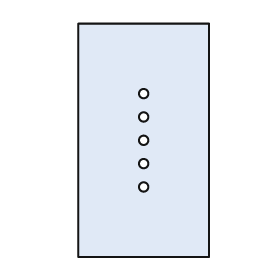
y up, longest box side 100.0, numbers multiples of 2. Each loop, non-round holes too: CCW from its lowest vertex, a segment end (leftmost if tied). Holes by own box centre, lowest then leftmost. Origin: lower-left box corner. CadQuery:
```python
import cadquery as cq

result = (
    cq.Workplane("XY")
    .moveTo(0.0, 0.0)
    .lineTo(56.0, 0.0)
    .lineTo(56.0, 100.0)
    .lineTo(0.0, 100.0)
    .close()
    .moveTo(28.0, 30.0)
    .circle(2.0)
    .moveTo(28.0, 40.0)
    .circle(2.0)
    .moveTo(28.0, 50.0)
    .circle(2.0)
    .moveTo(28.0, 60.0)
    .circle(2.0)
    .moveTo(28.0, 70.0)
    .circle(2.0)
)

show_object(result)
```